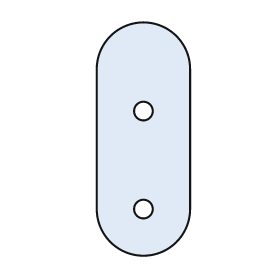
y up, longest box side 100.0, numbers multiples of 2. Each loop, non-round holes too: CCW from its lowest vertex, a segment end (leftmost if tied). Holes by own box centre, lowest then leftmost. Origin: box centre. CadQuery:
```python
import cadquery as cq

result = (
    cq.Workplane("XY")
    .moveTo(-20.0, -30.0)
    .threePointArc((0.0, -50.0), (20.0, -30.0))
    .lineTo(20.0, 30.0)
    .threePointArc((0.0, 50.0), (-20.0, 30.0))
    .close()
    .moveTo(0.0, -30.0)
    .circle(4.0)
    .moveTo(0.0, 12.0)
    .circle(4.0)
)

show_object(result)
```